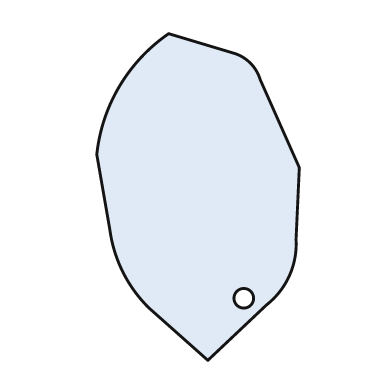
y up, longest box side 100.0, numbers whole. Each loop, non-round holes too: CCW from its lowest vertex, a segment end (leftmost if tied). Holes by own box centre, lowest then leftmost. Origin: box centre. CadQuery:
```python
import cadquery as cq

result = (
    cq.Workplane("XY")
    .moveTo(3.0, -50.0)
    .lineTo(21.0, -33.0)
    .threePointArc((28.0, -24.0), (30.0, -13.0))
    .lineTo(31.0, 9.0)
    .lineTo(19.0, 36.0)
    .threePointArc((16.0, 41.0), (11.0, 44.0))
    .lineTo(-9.0, 50.0)
    .threePointArc((-24.0, 34.0), (-31.0, 13.0))
    .lineTo(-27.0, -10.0)
    .threePointArc((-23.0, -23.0), (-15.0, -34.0))
    .close()
    .moveTo(14.0, -31.0)
    .circle(3.0)
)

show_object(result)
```